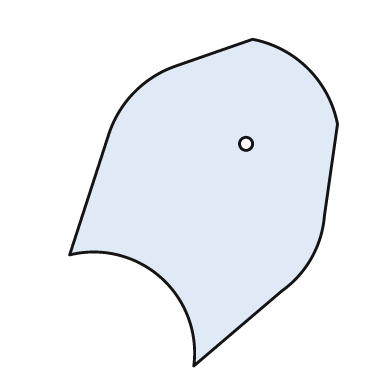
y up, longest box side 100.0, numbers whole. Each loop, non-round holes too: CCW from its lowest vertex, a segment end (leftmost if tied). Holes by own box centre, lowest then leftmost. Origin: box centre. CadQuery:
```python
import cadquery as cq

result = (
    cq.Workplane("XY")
    .moveTo(-3.0, -50.0)
    .lineTo(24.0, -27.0)
    .threePointArc((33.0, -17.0), (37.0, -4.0))
    .lineTo(41.0, 24.0)
    .threePointArc((32.0, 41.0), (15.0, 50.0))
    .lineTo(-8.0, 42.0)
    .threePointArc((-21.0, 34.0), (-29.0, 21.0))
    .lineTo(-41.0, -16.0)
    .threePointArc((-13.0, -23.0), (-3.0, -50.0))
    .close()
    .moveTo(13.0, 18.0)
    .circle(2.0)
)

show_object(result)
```